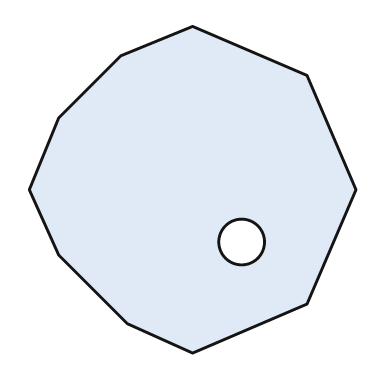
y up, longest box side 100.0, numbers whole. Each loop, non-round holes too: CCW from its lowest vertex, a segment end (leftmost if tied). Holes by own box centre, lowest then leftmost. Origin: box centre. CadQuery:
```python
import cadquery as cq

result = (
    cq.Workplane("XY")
    .moveTo(0.0, -50.0)
    .lineTo(35.0, -35.0)
    .lineTo(50.0, 0.0)
    .lineTo(35.0, 35.0)
    .lineTo(0.0, 50.0)
    .lineTo(-22.0, 41.0)
    .lineTo(-41.0, 22.0)
    .lineTo(-50.0, 0.0)
    .lineTo(-41.0, -20.0)
    .lineTo(-20.0, -41.0)
    .close()
    .moveTo(15.0, -16.0)
    .circle(7.0)
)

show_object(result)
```